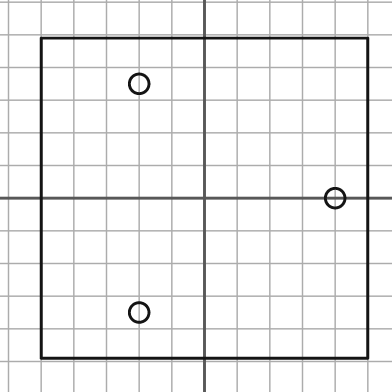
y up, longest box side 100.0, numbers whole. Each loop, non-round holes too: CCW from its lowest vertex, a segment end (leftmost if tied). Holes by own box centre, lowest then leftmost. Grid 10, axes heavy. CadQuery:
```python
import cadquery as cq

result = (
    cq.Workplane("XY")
    .moveTo(-50.0, -49.0)
    .lineTo(50.0, -49.0)
    .lineTo(50.0, 49.0)
    .lineTo(-50.0, 49.0)
    .close()
    .moveTo(-20.0, -35.0)
    .circle(3.0)
    .moveTo(40.0, 0.0)
    .circle(3.0)
    .moveTo(-20.0, 35.0)
    .circle(3.0)
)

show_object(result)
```